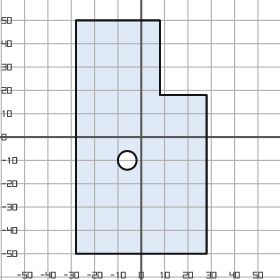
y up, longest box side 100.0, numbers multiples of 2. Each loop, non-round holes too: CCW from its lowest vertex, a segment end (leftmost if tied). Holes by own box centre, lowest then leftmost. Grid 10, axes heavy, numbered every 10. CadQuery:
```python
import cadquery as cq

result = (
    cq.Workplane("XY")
    .moveTo(-28.0, -50.0)
    .lineTo(28.0, -50.0)
    .lineTo(28.0, 18.0)
    .lineTo(8.0, 18.0)
    .lineTo(8.0, 50.0)
    .lineTo(-28.0, 50.0)
    .close()
    .moveTo(-6.0, -10.0)
    .circle(4.0)
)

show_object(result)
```